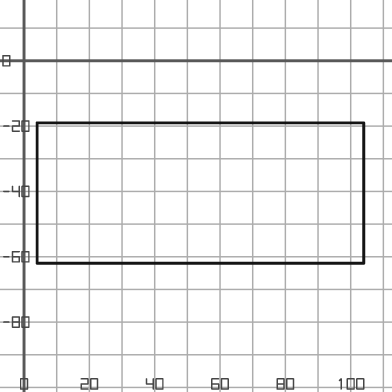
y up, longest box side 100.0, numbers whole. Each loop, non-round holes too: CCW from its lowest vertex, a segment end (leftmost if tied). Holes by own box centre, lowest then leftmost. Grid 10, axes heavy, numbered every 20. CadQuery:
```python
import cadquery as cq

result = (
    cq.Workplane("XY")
    .moveTo(4.0, -62.0)
    .lineTo(104.0, -62.0)
    .lineTo(104.0, -19.0)
    .lineTo(4.0, -19.0)
    .close()
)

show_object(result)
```